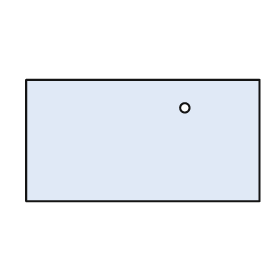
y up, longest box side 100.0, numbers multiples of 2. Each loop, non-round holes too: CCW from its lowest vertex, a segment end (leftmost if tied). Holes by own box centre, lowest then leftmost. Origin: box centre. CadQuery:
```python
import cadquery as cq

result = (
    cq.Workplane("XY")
    .moveTo(-50.0, -26.0)
    .lineTo(50.0, -26.0)
    .lineTo(50.0, 26.0)
    .lineTo(-50.0, 26.0)
    .close()
    .moveTo(18.0, 14.0)
    .circle(2.0)
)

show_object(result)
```